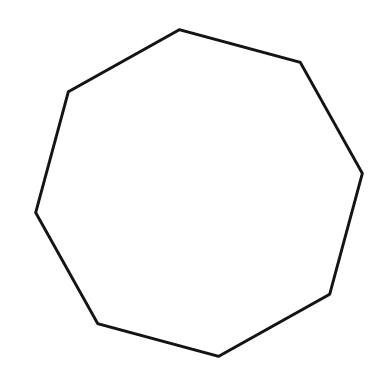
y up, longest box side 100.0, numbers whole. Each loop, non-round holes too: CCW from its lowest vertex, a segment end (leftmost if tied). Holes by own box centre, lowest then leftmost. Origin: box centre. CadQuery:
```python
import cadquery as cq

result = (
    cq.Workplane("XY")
    .moveTo(6.0, -50.0)
    .lineTo(40.0, -31.0)
    .lineTo(50.0, 6.0)
    .lineTo(31.0, 40.0)
    .lineTo(-6.0, 50.0)
    .lineTo(-40.0, 31.0)
    .lineTo(-50.0, -6.0)
    .lineTo(-31.0, -40.0)
    .close()
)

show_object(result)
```